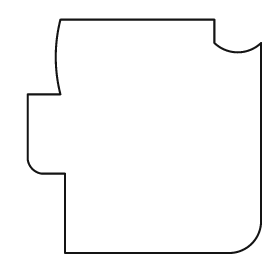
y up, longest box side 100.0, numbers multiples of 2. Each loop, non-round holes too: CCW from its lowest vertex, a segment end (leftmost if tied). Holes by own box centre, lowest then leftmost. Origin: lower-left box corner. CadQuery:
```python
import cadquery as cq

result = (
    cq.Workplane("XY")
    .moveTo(16.0, 0.0)
    .lineTo(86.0, 0.0)
    .threePointArc((96.0, 4.0), (100.0, 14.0))
    .lineTo(100.0, 90.0)
    .threePointArc((90.0, 86.0), (80.0, 90.0))
    .lineTo(80.0, 100.0)
    .lineTo(14.0, 100.0)
    .threePointArc((12.0, 84.0), (14.0, 68.0))
    .lineTo(0.0, 68.0)
    .lineTo(0.0, 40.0)
    .threePointArc((2.0, 36.0), (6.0, 34.0))
    .lineTo(16.0, 34.0)
    .close()
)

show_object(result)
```